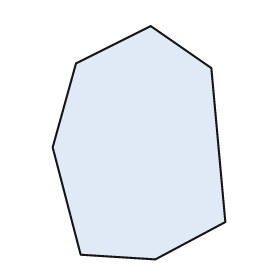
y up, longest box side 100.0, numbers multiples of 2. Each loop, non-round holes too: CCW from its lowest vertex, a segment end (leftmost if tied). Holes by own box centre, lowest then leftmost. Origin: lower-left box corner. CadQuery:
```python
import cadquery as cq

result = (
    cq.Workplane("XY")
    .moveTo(44.0, 0.0)
    .lineTo(74.0, 16.0)
    .lineTo(68.0, 82.0)
    .lineTo(42.0, 100.0)
    .lineTo(10.0, 84.0)
    .lineTo(0.0, 48.0)
    .lineTo(12.0, 2.0)
    .close()
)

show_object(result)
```